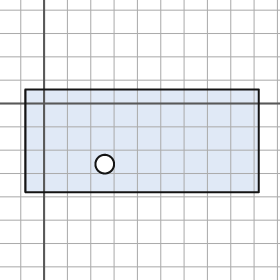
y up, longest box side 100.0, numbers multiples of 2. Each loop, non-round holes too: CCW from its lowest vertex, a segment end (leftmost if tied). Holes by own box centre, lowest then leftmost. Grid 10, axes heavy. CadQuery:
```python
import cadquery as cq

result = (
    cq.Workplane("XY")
    .moveTo(-8.0, -38.0)
    .lineTo(92.0, -38.0)
    .lineTo(92.0, 6.0)
    .lineTo(-8.0, 6.0)
    .close()
    .moveTo(26.0, -26.0)
    .circle(4.0)
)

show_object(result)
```